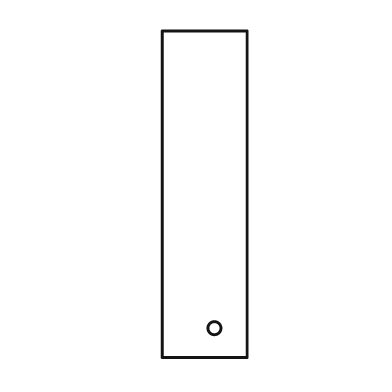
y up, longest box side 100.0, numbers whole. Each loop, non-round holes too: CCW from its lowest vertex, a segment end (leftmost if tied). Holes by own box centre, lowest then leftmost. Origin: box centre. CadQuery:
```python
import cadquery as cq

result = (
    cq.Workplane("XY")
    .moveTo(-13.0, -50.0)
    .lineTo(13.0, -50.0)
    .lineTo(13.0, 50.0)
    .lineTo(-13.0, 50.0)
    .close()
    .moveTo(3.0, -41.0)
    .circle(2.0)
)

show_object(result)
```